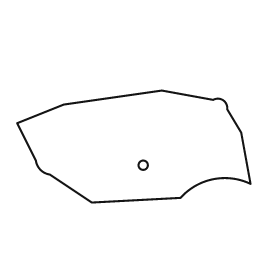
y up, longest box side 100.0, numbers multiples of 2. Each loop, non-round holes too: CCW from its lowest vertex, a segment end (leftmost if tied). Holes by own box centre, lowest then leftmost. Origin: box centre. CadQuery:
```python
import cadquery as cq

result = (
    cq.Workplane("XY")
    .moveTo(-18.0, -24.0)
    .lineTo(20.0, -22.0)
    .threePointArc((34.0, -14.0), (50.0, -16.0))
    .lineTo(46.0, 6.0)
    .lineTo(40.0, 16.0)
    .threePointArc((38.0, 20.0), (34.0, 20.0))
    .lineTo(12.0, 24.0)
    .lineTo(-30.0, 18.0)
    .lineTo(-50.0, 10.0)
    .lineTo(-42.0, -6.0)
    .threePointArc((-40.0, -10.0), (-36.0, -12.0))
    .close()
    .moveTo(4.0, -8.0)
    .circle(2.0)
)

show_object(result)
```